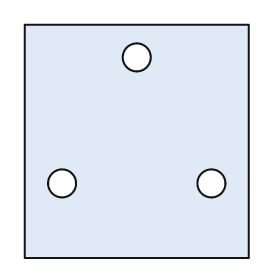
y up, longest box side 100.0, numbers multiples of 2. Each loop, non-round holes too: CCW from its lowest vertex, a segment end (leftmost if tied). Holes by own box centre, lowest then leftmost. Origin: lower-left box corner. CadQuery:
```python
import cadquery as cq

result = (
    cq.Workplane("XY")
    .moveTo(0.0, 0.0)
    .lineTo(96.0, 0.0)
    .lineTo(96.0, 100.0)
    .lineTo(0.0, 100.0)
    .close()
    .moveTo(16.0, 32.0)
    .circle(6.0)
    .moveTo(80.0, 32.0)
    .circle(6.0)
    .moveTo(48.0, 86.0)
    .circle(6.0)
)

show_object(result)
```